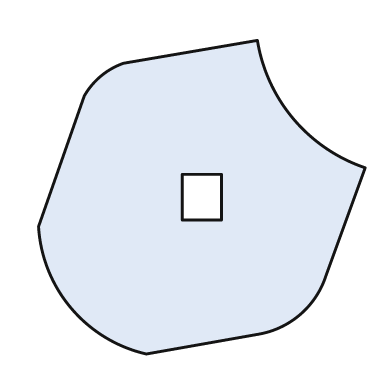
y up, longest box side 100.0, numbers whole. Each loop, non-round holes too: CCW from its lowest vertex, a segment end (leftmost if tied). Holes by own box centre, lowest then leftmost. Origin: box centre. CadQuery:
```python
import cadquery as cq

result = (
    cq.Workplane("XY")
    .moveTo(-17.0, -48.0)
    .lineTo(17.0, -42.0)
    .threePointArc((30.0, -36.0), (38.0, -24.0))
    .lineTo(50.0, 9.0)
    .threePointArc((28.0, 24.0), (17.0, 48.0))
    .lineTo(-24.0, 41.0)
    .threePointArc((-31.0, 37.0), (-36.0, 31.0))
    .lineTo(-50.0, -9.0)
    .threePointArc((-40.0, -34.0), (-17.0, -48.0))
    .close()
    .moveTo(-6.0, -7.0)
    .lineTo(6.0, -7.0)
    .lineTo(6.0, 7.0)
    .lineTo(-6.0, 7.0)
    .close()
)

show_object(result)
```